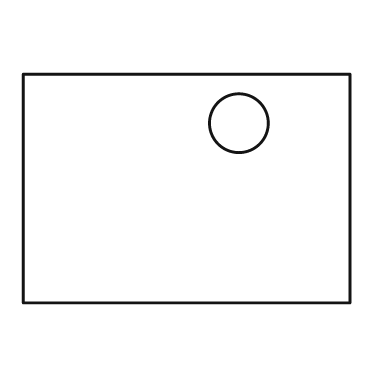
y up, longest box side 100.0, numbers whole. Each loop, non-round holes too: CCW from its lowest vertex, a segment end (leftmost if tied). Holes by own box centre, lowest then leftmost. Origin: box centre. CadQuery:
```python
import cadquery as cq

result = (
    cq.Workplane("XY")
    .moveTo(-50.0, -35.0)
    .lineTo(50.0, -35.0)
    .lineTo(50.0, 35.0)
    .lineTo(-50.0, 35.0)
    .close()
    .moveTo(16.0, 20.0)
    .circle(9.0)
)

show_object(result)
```